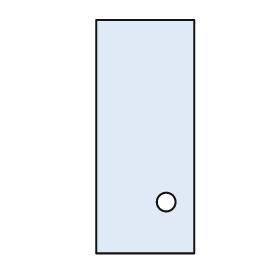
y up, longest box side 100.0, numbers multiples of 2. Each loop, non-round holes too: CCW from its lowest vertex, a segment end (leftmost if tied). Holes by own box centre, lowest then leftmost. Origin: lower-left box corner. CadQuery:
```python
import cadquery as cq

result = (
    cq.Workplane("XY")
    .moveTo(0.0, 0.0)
    .lineTo(42.0, 0.0)
    .lineTo(42.0, 100.0)
    .lineTo(0.0, 100.0)
    .close()
    .moveTo(30.0, 22.0)
    .circle(4.0)
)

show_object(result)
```